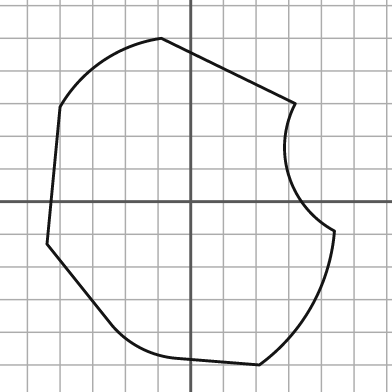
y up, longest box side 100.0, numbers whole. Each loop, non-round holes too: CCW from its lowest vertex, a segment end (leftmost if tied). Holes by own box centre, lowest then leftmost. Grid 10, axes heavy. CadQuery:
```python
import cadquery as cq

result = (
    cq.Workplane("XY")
    .moveTo(21.0, -50.0)
    .threePointArc((37.0, -32.0), (44.0, -9.0))
    .threePointArc((30.0, 8.0), (32.0, 30.0))
    .lineTo(-9.0, 50.0)
    .threePointArc((-27.0, 43.0), (-40.0, 29.0))
    .lineTo(-44.0, -13.0)
    .lineTo(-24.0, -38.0)
    .threePointArc((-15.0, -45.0), (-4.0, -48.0))
    .close()
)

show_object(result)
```